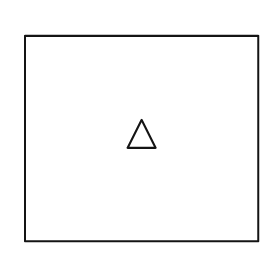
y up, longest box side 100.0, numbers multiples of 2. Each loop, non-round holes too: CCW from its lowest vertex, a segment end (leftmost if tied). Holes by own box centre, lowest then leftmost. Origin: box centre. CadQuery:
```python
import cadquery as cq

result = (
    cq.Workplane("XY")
    .moveTo(-50.0, -44.0)
    .lineTo(50.0, -44.0)
    .lineTo(50.0, 44.0)
    .lineTo(-50.0, 44.0)
    .close()
    .moveTo(-6.0, -4.0)
    .lineTo(6.0, -4.0)
    .lineTo(0.0, 8.0)
    .close()
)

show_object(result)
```